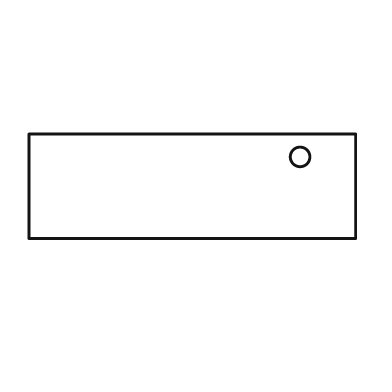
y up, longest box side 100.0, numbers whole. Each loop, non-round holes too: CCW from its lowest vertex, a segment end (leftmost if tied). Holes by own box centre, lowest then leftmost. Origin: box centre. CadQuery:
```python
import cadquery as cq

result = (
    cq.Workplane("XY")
    .moveTo(-50.0, -16.0)
    .lineTo(50.0, -16.0)
    .lineTo(50.0, 16.0)
    .lineTo(-50.0, 16.0)
    .close()
    .moveTo(33.0, 9.0)
    .circle(3.0)
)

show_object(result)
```